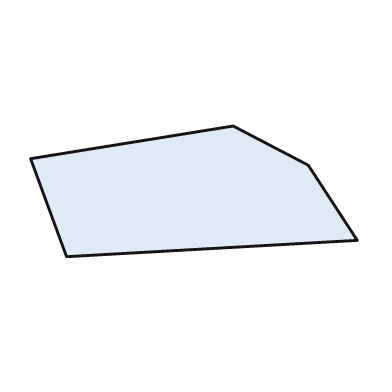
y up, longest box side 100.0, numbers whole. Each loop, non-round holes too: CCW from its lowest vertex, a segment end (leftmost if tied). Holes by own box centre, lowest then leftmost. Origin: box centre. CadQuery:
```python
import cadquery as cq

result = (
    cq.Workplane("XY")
    .moveTo(-39.0, -20.0)
    .lineTo(50.0, -15.0)
    .lineTo(35.0, 8.0)
    .lineTo(12.0, 20.0)
    .lineTo(-50.0, 10.0)
    .close()
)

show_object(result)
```